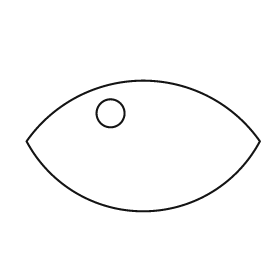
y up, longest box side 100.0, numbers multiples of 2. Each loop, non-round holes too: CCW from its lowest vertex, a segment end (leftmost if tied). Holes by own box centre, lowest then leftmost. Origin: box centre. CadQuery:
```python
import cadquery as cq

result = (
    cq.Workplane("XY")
    .moveTo(-50.0, 2.0)
    .threePointArc((0.0, -28.0), (50.0, 2.0))
    .threePointArc((0.0, 28.0), (-50.0, 2.0))
    .close()
    .moveTo(-14.0, 14.0)
    .circle(6.0)
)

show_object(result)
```